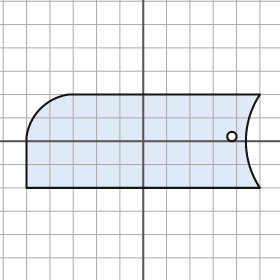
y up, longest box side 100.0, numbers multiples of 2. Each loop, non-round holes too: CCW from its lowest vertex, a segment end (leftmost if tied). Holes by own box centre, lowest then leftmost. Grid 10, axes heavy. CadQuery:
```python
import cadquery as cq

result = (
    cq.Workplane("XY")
    .moveTo(-50.0, -20.0)
    .lineTo(50.0, -20.0)
    .threePointArc((44.0, 0.0), (50.0, 20.0))
    .lineTo(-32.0, 20.0)
    .threePointArc((-44.0, 14.0), (-50.0, 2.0))
    .close()
    .moveTo(38.0, 2.0)
    .circle(2.0)
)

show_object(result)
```